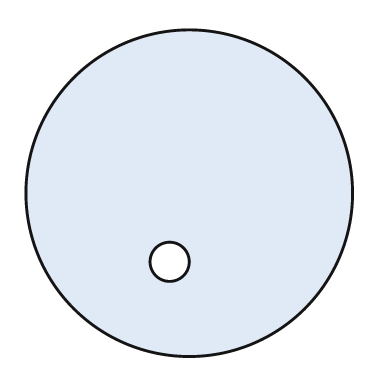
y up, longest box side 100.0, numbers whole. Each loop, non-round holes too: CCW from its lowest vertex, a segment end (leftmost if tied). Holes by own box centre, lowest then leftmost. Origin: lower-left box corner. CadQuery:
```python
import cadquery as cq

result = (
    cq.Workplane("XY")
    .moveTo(50.0, 50.0)
    .circle(50.0)
    .moveTo(44.0, 29.0)
    .circle(6.0)
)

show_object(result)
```